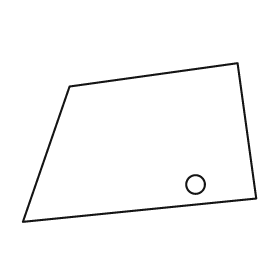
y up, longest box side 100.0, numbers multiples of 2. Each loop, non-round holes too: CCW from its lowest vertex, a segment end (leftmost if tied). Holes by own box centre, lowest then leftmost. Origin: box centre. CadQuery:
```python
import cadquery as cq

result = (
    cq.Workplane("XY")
    .moveTo(-50.0, -34.0)
    .lineTo(50.0, -24.0)
    .lineTo(42.0, 34.0)
    .lineTo(-30.0, 24.0)
    .close()
    .moveTo(24.0, -18.0)
    .circle(4.0)
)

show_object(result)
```